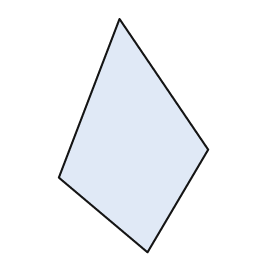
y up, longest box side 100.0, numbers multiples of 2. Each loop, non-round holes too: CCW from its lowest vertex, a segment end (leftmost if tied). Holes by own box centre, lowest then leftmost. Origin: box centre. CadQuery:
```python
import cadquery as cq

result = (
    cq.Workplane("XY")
    .moveTo(6.0, -50.0)
    .lineTo(32.0, -6.0)
    .lineTo(-6.0, 50.0)
    .lineTo(-32.0, -18.0)
    .close()
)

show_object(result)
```